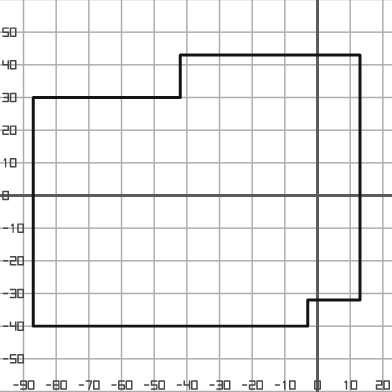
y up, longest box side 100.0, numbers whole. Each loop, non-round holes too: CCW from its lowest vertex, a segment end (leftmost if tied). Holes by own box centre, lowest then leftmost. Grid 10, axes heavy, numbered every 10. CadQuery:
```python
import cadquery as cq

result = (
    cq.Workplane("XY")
    .moveTo(-87.0, -40.0)
    .lineTo(-3.0, -40.0)
    .lineTo(-3.0, -32.0)
    .lineTo(13.0, -32.0)
    .lineTo(13.0, 43.0)
    .lineTo(-42.0, 43.0)
    .lineTo(-42.0, 30.0)
    .lineTo(-87.0, 30.0)
    .close()
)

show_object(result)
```